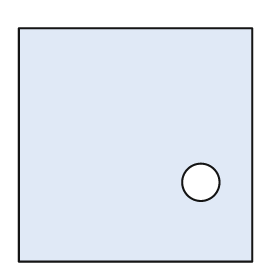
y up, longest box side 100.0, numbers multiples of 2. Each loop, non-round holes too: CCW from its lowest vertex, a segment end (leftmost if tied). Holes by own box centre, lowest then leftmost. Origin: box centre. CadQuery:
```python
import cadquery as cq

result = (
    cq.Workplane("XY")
    .moveTo(-50.0, -50.0)
    .lineTo(50.0, -50.0)
    .lineTo(50.0, 50.0)
    .lineTo(-50.0, 50.0)
    .close()
    .moveTo(28.0, -16.0)
    .circle(8.0)
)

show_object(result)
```